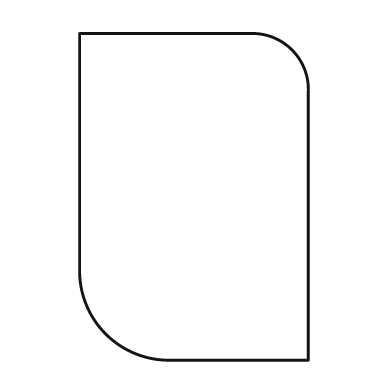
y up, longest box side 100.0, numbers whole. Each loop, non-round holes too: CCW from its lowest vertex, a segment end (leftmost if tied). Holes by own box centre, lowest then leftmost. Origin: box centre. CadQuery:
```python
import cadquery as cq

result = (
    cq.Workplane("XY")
    .moveTo(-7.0, -50.0)
    .lineTo(35.0, -50.0)
    .lineTo(35.0, 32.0)
    .threePointArc((30.0, 45.0), (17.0, 50.0))
    .lineTo(-35.0, 50.0)
    .lineTo(-35.0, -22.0)
    .threePointArc((-27.0, -42.0), (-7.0, -50.0))
    .close()
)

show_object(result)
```